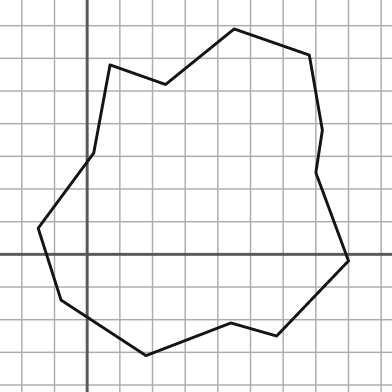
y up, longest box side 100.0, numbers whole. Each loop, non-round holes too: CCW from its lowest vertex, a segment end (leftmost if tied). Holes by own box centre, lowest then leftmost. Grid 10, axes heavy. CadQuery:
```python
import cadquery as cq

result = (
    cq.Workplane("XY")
    .moveTo(18.0, -31.0)
    .lineTo(44.0, -21.0)
    .lineTo(58.0, -25.0)
    .lineTo(80.0, -2.0)
    .lineTo(70.0, 25.0)
    .lineTo(72.0, 38.0)
    .lineTo(68.0, 61.0)
    .lineTo(45.0, 69.0)
    .lineTo(24.0, 52.0)
    .lineTo(7.0, 58.0)
    .lineTo(2.0, 31.0)
    .lineTo(-15.0, 8.0)
    .lineTo(-8.0, -14.0)
    .close()
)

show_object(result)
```